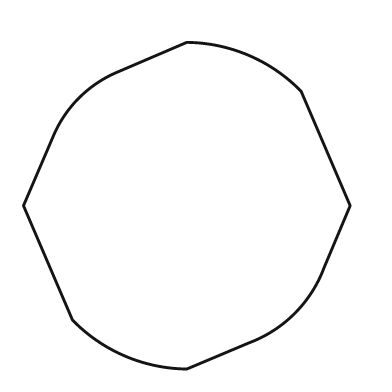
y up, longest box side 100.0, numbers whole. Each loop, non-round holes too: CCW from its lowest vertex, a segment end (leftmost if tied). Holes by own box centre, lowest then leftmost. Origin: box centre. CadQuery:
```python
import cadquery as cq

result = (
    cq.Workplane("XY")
    .moveTo(0.0, -50.0)
    .lineTo(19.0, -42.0)
    .threePointArc((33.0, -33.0), (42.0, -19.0))
    .lineTo(50.0, 0.0)
    .lineTo(35.0, 35.0)
    .threePointArc((19.0, 46.0), (0.0, 50.0))
    .lineTo(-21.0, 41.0)
    .threePointArc((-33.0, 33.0), (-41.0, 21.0))
    .lineTo(-50.0, 0.0)
    .lineTo(-35.0, -35.0)
    .threePointArc((-19.0, -46.0), (0.0, -50.0))
    .close()
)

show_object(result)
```